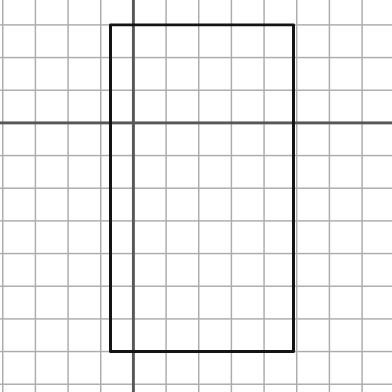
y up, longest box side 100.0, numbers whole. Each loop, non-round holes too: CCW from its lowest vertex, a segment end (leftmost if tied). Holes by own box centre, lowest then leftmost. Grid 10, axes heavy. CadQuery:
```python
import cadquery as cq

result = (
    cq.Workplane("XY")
    .moveTo(-7.0, -70.0)
    .lineTo(49.0, -70.0)
    .lineTo(49.0, 30.0)
    .lineTo(-7.0, 30.0)
    .close()
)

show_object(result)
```